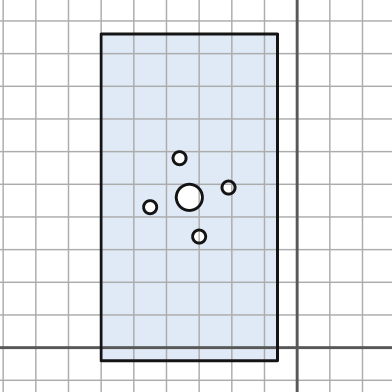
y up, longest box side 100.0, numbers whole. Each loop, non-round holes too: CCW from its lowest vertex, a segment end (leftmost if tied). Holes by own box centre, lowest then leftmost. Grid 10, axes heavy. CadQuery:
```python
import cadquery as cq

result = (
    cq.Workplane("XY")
    .moveTo(-60.0, -4.0)
    .lineTo(-6.0, -4.0)
    .lineTo(-6.0, 96.0)
    .lineTo(-60.0, 96.0)
    .close()
    .moveTo(-30.0, 34.0)
    .circle(2.0)
    .moveTo(-45.0, 43.0)
    .circle(2.0)
    .moveTo(-33.0, 46.0)
    .circle(4.0)
    .moveTo(-21.0, 49.0)
    .circle(2.0)
    .moveTo(-36.0, 58.0)
    .circle(2.0)
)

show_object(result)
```